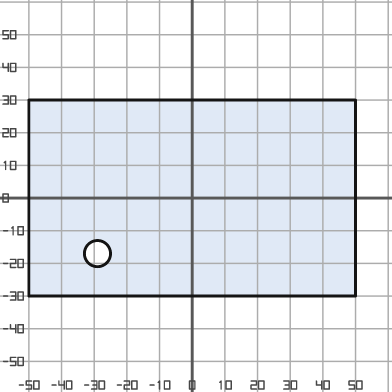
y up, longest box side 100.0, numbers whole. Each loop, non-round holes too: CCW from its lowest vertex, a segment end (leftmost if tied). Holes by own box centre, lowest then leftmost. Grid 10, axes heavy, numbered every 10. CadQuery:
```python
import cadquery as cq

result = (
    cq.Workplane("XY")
    .moveTo(-50.0, -30.0)
    .lineTo(50.0, -30.0)
    .lineTo(50.0, 30.0)
    .lineTo(-50.0, 30.0)
    .close()
    .moveTo(-29.0, -17.0)
    .circle(4.0)
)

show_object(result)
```